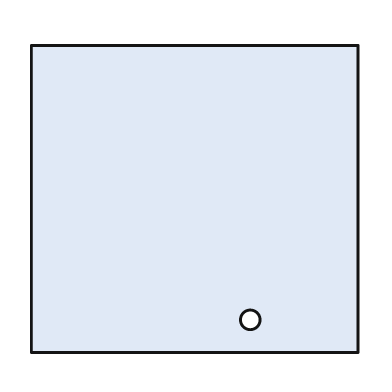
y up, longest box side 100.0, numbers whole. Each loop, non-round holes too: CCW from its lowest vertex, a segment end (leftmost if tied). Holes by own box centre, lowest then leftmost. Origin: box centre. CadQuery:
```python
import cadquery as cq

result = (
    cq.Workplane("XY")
    .moveTo(-50.0, -47.0)
    .lineTo(50.0, -47.0)
    .lineTo(50.0, 47.0)
    .lineTo(-50.0, 47.0)
    .close()
    .moveTo(17.0, -37.0)
    .circle(3.0)
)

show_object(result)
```